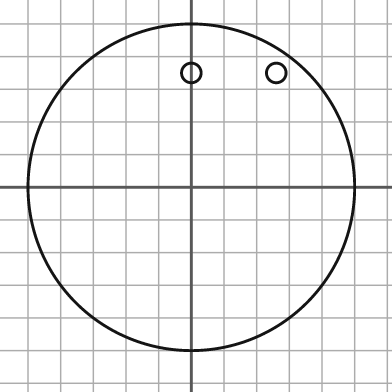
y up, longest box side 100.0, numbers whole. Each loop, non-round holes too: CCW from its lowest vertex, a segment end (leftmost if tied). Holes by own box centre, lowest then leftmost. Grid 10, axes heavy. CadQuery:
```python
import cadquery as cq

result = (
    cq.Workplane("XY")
    .moveTo(0.0, 0.0)
    .circle(50.0)
    .moveTo(0.0, 35.0)
    .circle(3.0)
    .moveTo(26.0, 35.0)
    .circle(3.0)
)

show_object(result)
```